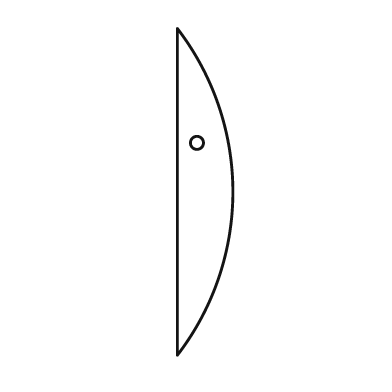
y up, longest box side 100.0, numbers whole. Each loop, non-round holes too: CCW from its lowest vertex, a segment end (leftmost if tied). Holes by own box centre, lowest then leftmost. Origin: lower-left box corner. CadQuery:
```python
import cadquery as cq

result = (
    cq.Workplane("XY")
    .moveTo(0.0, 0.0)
    .threePointArc((17.0, 50.0), (0.0, 100.0))
    .close()
    .moveTo(6.0, 65.0)
    .circle(2.0)
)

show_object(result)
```